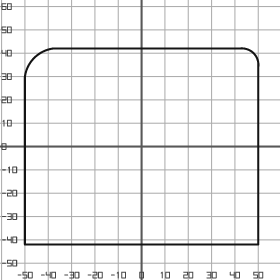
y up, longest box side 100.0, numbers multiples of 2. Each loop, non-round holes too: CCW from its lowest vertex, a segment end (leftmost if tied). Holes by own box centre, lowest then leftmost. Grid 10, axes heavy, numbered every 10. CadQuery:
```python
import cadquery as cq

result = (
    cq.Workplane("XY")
    .moveTo(-50.0, -42.0)
    .lineTo(50.0, -42.0)
    .lineTo(50.0, 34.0)
    .threePointArc((48.0, 40.0), (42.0, 42.0))
    .lineTo(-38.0, 42.0)
    .threePointArc((-46.0, 38.0), (-50.0, 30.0))
    .close()
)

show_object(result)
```